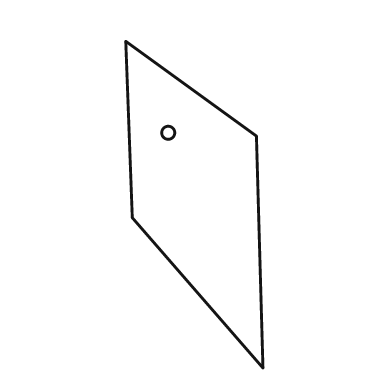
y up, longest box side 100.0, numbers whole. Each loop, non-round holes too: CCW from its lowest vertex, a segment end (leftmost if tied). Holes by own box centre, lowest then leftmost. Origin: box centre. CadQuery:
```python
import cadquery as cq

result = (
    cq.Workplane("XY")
    .moveTo(21.0, -50.0)
    .lineTo(19.0, 21.0)
    .lineTo(-21.0, 50.0)
    .lineTo(-19.0, -4.0)
    .close()
    .moveTo(-8.0, 22.0)
    .circle(2.0)
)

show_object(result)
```